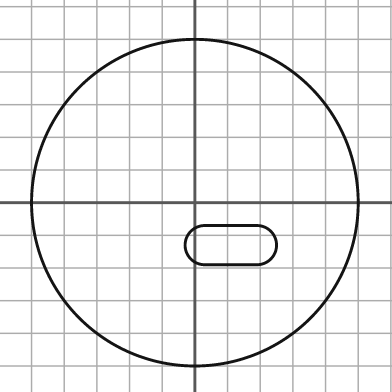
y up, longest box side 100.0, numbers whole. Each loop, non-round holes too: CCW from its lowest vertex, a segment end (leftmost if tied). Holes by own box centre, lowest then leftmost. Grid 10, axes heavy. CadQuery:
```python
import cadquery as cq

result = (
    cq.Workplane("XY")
    .moveTo(0.0, 0.0)
    .circle(50.0)
    .moveTo(3.0, -19.0)
    .lineTo(19.0, -19.0)
    .threePointArc((25.0, -13.0), (19.0, -7.0))
    .lineTo(3.0, -7.0)
    .threePointArc((-3.0, -13.0), (3.0, -19.0))
    .close()
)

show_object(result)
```